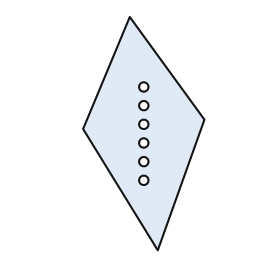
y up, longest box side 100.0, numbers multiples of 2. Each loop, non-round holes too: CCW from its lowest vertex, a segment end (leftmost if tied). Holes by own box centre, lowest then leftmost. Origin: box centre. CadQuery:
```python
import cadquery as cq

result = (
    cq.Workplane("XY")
    .moveTo(6.0, -50.0)
    .lineTo(26.0, 6.0)
    .lineTo(-6.0, 50.0)
    .lineTo(-26.0, 2.0)
    .close()
    .moveTo(0.0, -20.0)
    .circle(2.0)
    .moveTo(0.0, -12.0)
    .circle(2.0)
    .moveTo(0.0, -4.0)
    .circle(2.0)
    .moveTo(0.0, 4.0)
    .circle(2.0)
    .moveTo(0.0, 12.0)
    .circle(2.0)
    .moveTo(0.0, 20.0)
    .circle(2.0)
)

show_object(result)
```